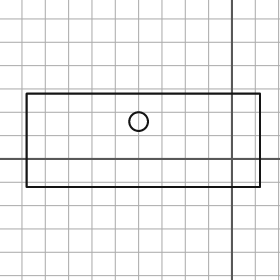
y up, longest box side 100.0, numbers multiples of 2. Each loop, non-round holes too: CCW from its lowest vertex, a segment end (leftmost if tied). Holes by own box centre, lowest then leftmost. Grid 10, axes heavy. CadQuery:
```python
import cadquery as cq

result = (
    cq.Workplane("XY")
    .moveTo(-88.0, -12.0)
    .lineTo(12.0, -12.0)
    .lineTo(12.0, 28.0)
    .lineTo(-88.0, 28.0)
    .close()
    .moveTo(-40.0, 16.0)
    .circle(4.0)
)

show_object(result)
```